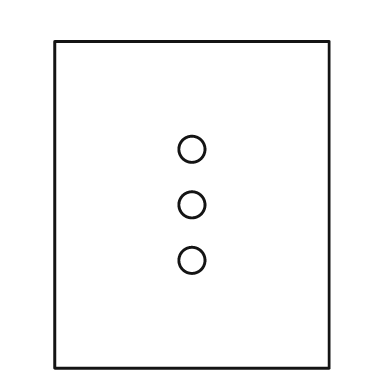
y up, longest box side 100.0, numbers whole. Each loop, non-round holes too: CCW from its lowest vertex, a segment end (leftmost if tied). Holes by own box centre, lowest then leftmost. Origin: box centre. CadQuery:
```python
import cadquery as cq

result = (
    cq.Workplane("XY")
    .moveTo(-42.0, -50.0)
    .lineTo(42.0, -50.0)
    .lineTo(42.0, 50.0)
    .lineTo(-42.0, 50.0)
    .close()
    .moveTo(0.0, -17.0)
    .circle(4.0)
    .moveTo(0.0, 0.0)
    .circle(4.0)
    .moveTo(0.0, 17.0)
    .circle(4.0)
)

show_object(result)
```